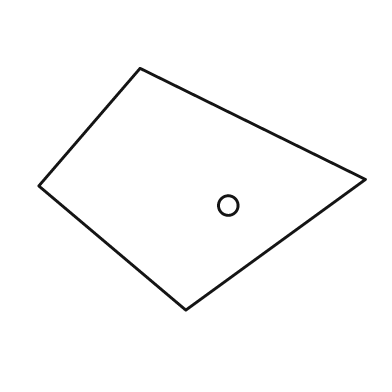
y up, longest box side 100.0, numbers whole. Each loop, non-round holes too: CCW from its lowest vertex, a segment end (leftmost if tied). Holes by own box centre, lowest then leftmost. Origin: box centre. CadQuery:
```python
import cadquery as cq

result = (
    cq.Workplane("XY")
    .moveTo(-5.0, -37.0)
    .lineTo(50.0, 3.0)
    .lineTo(-19.0, 37.0)
    .lineTo(-50.0, 1.0)
    .close()
    .moveTo(8.0, -5.0)
    .circle(3.0)
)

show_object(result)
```